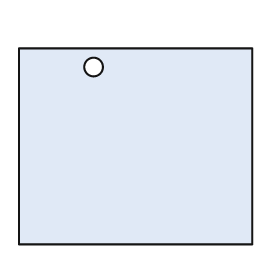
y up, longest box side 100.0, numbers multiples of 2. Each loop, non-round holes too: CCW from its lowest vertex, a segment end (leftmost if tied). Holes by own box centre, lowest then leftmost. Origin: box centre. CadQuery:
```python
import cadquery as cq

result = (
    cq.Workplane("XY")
    .moveTo(-50.0, -42.0)
    .lineTo(50.0, -42.0)
    .lineTo(50.0, 42.0)
    .lineTo(-50.0, 42.0)
    .close()
    .moveTo(-18.0, 34.0)
    .circle(4.0)
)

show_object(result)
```